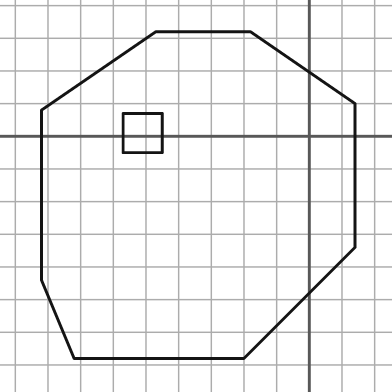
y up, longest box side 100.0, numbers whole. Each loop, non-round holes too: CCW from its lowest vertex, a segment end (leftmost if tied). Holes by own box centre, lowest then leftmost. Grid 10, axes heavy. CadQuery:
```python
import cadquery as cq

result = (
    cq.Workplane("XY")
    .moveTo(-72.0, -68.0)
    .lineTo(-20.0, -68.0)
    .lineTo(14.0, -34.0)
    .lineTo(14.0, 10.0)
    .lineTo(-18.0, 32.0)
    .lineTo(-47.0, 32.0)
    .lineTo(-82.0, 8.0)
    .lineTo(-82.0, -44.0)
    .close()
    .moveTo(-57.0, -5.0)
    .lineTo(-45.0, -5.0)
    .lineTo(-45.0, 7.0)
    .lineTo(-57.0, 7.0)
    .close()
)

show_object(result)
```